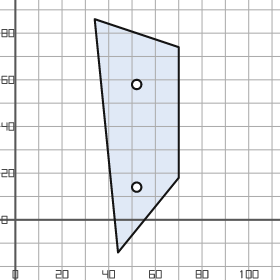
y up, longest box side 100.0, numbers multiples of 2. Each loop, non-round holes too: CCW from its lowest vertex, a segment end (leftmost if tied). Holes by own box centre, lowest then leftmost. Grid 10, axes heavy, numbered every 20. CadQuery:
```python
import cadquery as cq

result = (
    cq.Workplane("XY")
    .moveTo(44.0, -14.0)
    .lineTo(70.0, 18.0)
    .lineTo(70.0, 74.0)
    .lineTo(34.0, 86.0)
    .close()
    .moveTo(52.0, 14.0)
    .circle(2.0)
    .moveTo(52.0, 58.0)
    .circle(2.0)
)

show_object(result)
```